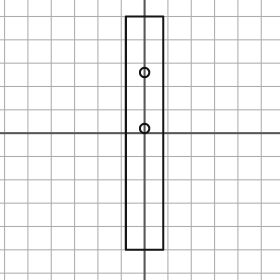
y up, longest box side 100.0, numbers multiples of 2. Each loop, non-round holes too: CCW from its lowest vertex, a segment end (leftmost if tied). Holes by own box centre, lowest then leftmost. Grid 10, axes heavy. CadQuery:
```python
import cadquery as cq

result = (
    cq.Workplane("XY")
    .moveTo(-8.0, -50.0)
    .lineTo(8.0, -50.0)
    .lineTo(8.0, 50.0)
    .lineTo(-8.0, 50.0)
    .close()
    .moveTo(0.0, 2.0)
    .circle(2.0)
    .moveTo(0.0, 26.0)
    .circle(2.0)
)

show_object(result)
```